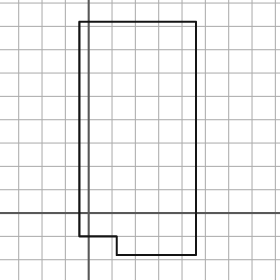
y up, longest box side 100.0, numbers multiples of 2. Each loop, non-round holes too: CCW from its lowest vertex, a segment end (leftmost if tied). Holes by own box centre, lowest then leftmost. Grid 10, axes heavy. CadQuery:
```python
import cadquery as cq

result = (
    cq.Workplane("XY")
    .moveTo(12.0, -18.0)
    .lineTo(46.0, -18.0)
    .lineTo(46.0, 82.0)
    .lineTo(-4.0, 82.0)
    .lineTo(-4.0, -10.0)
    .lineTo(12.0, -10.0)
    .close()
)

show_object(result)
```